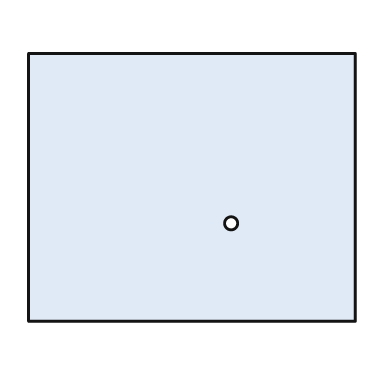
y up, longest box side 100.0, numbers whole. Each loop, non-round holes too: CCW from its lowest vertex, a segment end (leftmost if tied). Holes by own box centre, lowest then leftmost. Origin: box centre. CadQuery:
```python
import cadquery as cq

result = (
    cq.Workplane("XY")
    .moveTo(-50.0, -41.0)
    .lineTo(50.0, -41.0)
    .lineTo(50.0, 41.0)
    .lineTo(-50.0, 41.0)
    .close()
    .moveTo(12.0, -11.0)
    .circle(2.0)
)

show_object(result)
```